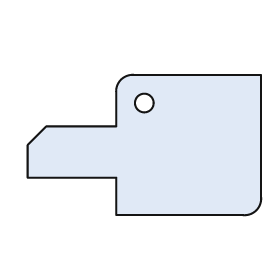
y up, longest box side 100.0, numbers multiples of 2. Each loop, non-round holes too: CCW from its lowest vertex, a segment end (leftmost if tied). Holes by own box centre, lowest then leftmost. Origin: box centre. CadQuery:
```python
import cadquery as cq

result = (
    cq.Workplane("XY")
    .moveTo(-12.0, -30.0)
    .lineTo(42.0, -30.0)
    .threePointArc((48.0, -28.0), (50.0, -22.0))
    .lineTo(50.0, 30.0)
    .lineTo(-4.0, 30.0)
    .threePointArc((-10.0, 28.0), (-12.0, 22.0))
    .lineTo(-12.0, 8.0)
    .lineTo(-42.0, 8.0)
    .lineTo(-50.0, 0.0)
    .lineTo(-50.0, -14.0)
    .lineTo(-12.0, -14.0)
    .close()
    .moveTo(0.0, 18.0)
    .circle(4.0)
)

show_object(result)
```